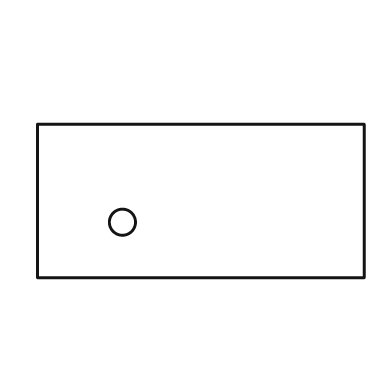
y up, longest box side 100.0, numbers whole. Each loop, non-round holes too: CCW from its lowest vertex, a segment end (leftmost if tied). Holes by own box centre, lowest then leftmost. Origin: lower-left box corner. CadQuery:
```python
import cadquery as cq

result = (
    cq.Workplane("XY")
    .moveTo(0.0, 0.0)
    .lineTo(100.0, 0.0)
    .lineTo(100.0, 47.0)
    .lineTo(0.0, 47.0)
    .close()
    .moveTo(26.0, 17.0)
    .circle(4.0)
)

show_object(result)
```